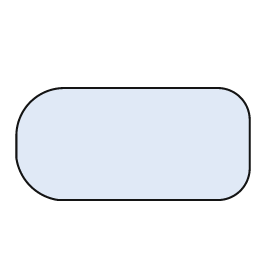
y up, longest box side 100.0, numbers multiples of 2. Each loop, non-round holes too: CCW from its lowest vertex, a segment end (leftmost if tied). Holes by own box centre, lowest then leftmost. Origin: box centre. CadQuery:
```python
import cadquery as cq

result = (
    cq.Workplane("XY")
    .moveTo(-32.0, -24.0)
    .lineTo(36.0, -24.0)
    .threePointArc((46.0, -20.0), (50.0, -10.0))
    .lineTo(50.0, 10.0)
    .threePointArc((46.0, 20.0), (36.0, 24.0))
    .lineTo(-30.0, 24.0)
    .threePointArc((-44.0, 18.0), (-50.0, 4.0))
    .lineTo(-50.0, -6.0)
    .threePointArc((-44.0, -18.0), (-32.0, -24.0))
    .close()
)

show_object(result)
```